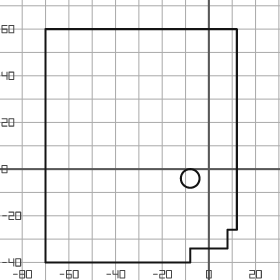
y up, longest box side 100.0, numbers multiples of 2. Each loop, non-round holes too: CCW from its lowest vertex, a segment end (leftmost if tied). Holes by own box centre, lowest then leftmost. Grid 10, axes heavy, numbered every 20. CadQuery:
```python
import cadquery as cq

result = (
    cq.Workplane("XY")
    .moveTo(-70.0, -40.0)
    .lineTo(-8.0, -40.0)
    .lineTo(-8.0, -34.0)
    .lineTo(8.0, -34.0)
    .lineTo(8.0, -26.0)
    .lineTo(12.0, -26.0)
    .lineTo(12.0, 60.0)
    .lineTo(-70.0, 60.0)
    .close()
    .moveTo(-8.0, -4.0)
    .circle(4.0)
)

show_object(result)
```